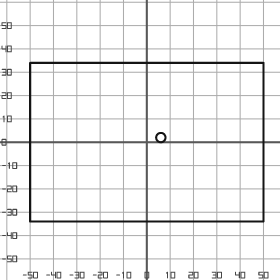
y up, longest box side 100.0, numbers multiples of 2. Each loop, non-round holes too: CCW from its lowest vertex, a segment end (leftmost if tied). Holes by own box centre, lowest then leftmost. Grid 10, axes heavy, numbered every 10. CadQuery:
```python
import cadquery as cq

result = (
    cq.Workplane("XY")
    .moveTo(-50.0, -34.0)
    .lineTo(50.0, -34.0)
    .lineTo(50.0, 34.0)
    .lineTo(-50.0, 34.0)
    .close()
    .moveTo(6.0, 2.0)
    .circle(2.0)
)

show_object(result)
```